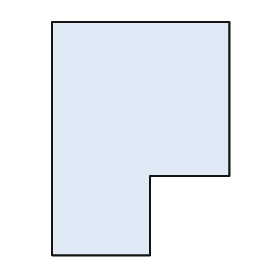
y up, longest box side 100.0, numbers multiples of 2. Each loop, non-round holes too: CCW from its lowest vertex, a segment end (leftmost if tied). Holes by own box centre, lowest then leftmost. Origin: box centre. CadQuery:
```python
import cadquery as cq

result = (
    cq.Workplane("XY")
    .moveTo(-38.0, -50.0)
    .lineTo(4.0, -50.0)
    .lineTo(4.0, -16.0)
    .lineTo(38.0, -16.0)
    .lineTo(38.0, 50.0)
    .lineTo(-38.0, 50.0)
    .close()
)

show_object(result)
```